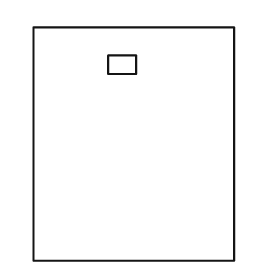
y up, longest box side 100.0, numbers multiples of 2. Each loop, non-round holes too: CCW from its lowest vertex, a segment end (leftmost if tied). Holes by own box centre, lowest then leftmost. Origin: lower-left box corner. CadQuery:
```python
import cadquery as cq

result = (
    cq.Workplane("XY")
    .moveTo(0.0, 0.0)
    .lineTo(86.0, 0.0)
    .lineTo(86.0, 100.0)
    .lineTo(0.0, 100.0)
    .close()
    .moveTo(32.0, 80.0)
    .lineTo(44.0, 80.0)
    .lineTo(44.0, 88.0)
    .lineTo(32.0, 88.0)
    .close()
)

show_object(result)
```